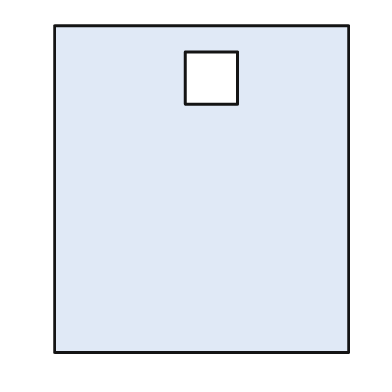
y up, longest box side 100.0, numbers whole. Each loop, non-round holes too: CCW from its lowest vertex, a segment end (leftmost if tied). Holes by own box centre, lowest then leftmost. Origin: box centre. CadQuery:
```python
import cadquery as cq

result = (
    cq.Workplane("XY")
    .moveTo(-45.0, -50.0)
    .lineTo(45.0, -50.0)
    .lineTo(45.0, 50.0)
    .lineTo(-45.0, 50.0)
    .close()
    .moveTo(-5.0, 26.0)
    .lineTo(11.0, 26.0)
    .lineTo(11.0, 42.0)
    .lineTo(-5.0, 42.0)
    .close()
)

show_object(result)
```